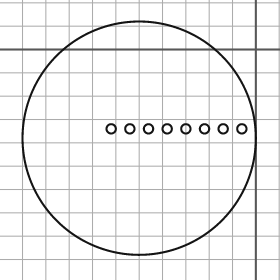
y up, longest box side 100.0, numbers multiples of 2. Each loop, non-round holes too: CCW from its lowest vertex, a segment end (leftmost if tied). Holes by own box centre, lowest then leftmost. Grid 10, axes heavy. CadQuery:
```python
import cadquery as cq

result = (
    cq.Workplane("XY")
    .moveTo(-50.0, -38.0)
    .circle(50.0)
    .moveTo(-62.0, -34.0)
    .circle(2.0)
    .moveTo(-54.0, -34.0)
    .circle(2.0)
    .moveTo(-46.0, -34.0)
    .circle(2.0)
    .moveTo(-38.0, -34.0)
    .circle(2.0)
    .moveTo(-30.0, -34.0)
    .circle(2.0)
    .moveTo(-22.0, -34.0)
    .circle(2.0)
    .moveTo(-14.0, -34.0)
    .circle(2.0)
    .moveTo(-6.0, -34.0)
    .circle(2.0)
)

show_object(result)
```